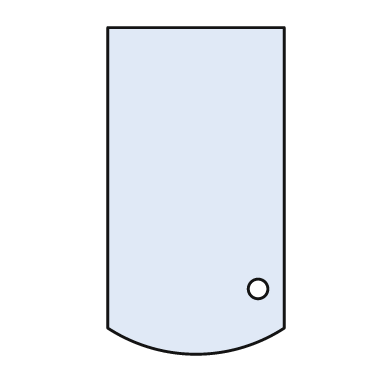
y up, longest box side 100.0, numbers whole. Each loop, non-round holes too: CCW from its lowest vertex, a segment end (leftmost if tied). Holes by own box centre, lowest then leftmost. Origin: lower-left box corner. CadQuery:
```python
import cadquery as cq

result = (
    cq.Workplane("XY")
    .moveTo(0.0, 8.0)
    .threePointArc((27.0, 0.0), (54.0, 8.0))
    .lineTo(54.0, 100.0)
    .lineTo(0.0, 100.0)
    .close()
    .moveTo(46.0, 20.0)
    .circle(3.0)
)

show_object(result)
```